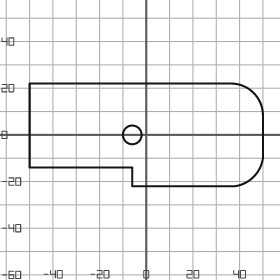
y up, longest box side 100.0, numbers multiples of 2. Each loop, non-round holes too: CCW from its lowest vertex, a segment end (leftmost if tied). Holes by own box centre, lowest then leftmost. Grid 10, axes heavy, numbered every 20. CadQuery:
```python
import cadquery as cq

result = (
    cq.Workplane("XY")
    .moveTo(-6.0, -22.0)
    .lineTo(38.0, -22.0)
    .threePointArc((46.0, -18.0), (50.0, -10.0))
    .lineTo(50.0, 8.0)
    .threePointArc((46.0, 18.0), (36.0, 22.0))
    .lineTo(-50.0, 22.0)
    .lineTo(-50.0, -14.0)
    .lineTo(-6.0, -14.0)
    .close()
    .moveTo(-6.0, 0.0)
    .circle(4.0)
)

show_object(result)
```